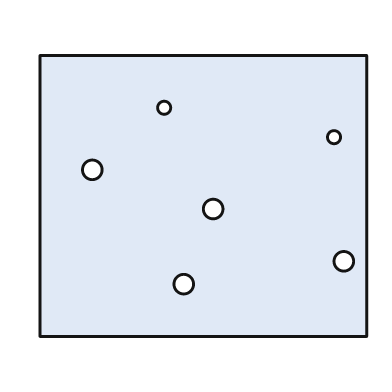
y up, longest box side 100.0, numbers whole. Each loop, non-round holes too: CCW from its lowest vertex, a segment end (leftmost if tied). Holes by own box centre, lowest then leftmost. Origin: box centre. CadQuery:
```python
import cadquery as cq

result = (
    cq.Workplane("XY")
    .moveTo(-50.0, -43.0)
    .lineTo(50.0, -43.0)
    .lineTo(50.0, 43.0)
    .lineTo(-50.0, 43.0)
    .close()
    .moveTo(-6.0, -27.0)
    .circle(3.0)
    .moveTo(43.0, -20.0)
    .circle(3.0)
    .moveTo(3.0, -4.0)
    .circle(3.0)
    .moveTo(-34.0, 8.0)
    .circle(3.0)
    .moveTo(40.0, 18.0)
    .circle(2.0)
    .moveTo(-12.0, 27.0)
    .circle(2.0)
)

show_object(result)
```